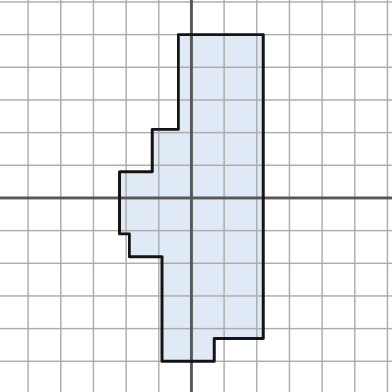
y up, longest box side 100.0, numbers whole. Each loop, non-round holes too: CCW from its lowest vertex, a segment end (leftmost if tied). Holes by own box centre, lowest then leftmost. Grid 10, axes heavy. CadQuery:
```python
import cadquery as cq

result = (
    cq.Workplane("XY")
    .moveTo(-9.0, -50.0)
    .lineTo(7.0, -50.0)
    .lineTo(7.0, -43.0)
    .lineTo(22.0, -43.0)
    .lineTo(22.0, 50.0)
    .lineTo(-4.0, 50.0)
    .lineTo(-4.0, 21.0)
    .lineTo(-12.0, 21.0)
    .lineTo(-12.0, 8.0)
    .lineTo(-22.0, 8.0)
    .lineTo(-22.0, -11.0)
    .lineTo(-19.0, -11.0)
    .lineTo(-19.0, -18.0)
    .lineTo(-9.0, -18.0)
    .close()
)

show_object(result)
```